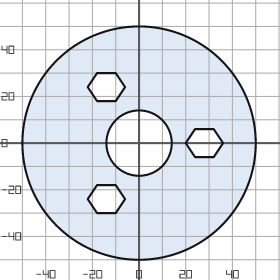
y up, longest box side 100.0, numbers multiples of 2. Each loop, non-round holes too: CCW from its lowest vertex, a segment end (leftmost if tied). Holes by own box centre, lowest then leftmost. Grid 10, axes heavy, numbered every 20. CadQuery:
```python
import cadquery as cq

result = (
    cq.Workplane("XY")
    .moveTo(0.0, 0.0)
    .circle(50.0)
    .moveTo(-18.0, -30.0)
    .lineTo(-10.0, -30.0)
    .lineTo(-6.0, -24.0)
    .lineTo(-10.0, -18.0)
    .lineTo(-18.0, -18.0)
    .lineTo(-22.0, -24.0)
    .close()
    .moveTo(0.0, 0.0)
    .circle(14.0)
    .moveTo(24.0, -6.0)
    .lineTo(32.0, -6.0)
    .lineTo(36.0, 0.0)
    .lineTo(32.0, 6.0)
    .lineTo(24.0, 6.0)
    .lineTo(20.0, 0.0)
    .close()
    .moveTo(-18.0, 18.0)
    .lineTo(-10.0, 18.0)
    .lineTo(-6.0, 24.0)
    .lineTo(-10.0, 30.0)
    .lineTo(-18.0, 30.0)
    .lineTo(-22.0, 24.0)
    .close()
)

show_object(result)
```